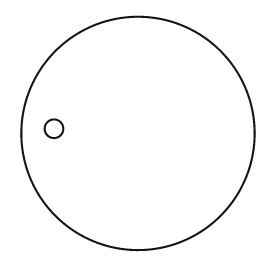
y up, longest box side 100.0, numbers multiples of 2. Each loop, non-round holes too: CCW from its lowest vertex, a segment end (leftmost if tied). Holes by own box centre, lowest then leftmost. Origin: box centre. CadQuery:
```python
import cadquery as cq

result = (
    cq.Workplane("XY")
    .moveTo(0.0, 0.0)
    .circle(50.0)
    .moveTo(-36.0, 2.0)
    .circle(4.0)
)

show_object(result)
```